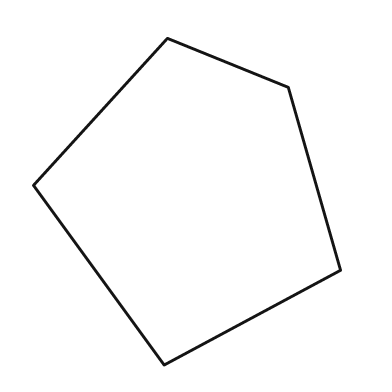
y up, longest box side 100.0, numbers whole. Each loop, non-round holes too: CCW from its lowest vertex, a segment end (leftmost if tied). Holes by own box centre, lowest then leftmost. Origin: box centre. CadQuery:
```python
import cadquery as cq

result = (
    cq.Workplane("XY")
    .moveTo(-7.0, -50.0)
    .lineTo(47.0, -21.0)
    .lineTo(31.0, 35.0)
    .lineTo(-6.0, 50.0)
    .lineTo(-47.0, 5.0)
    .close()
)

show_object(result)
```